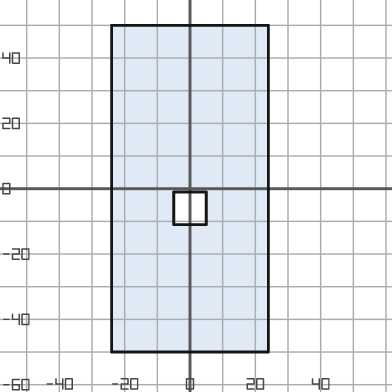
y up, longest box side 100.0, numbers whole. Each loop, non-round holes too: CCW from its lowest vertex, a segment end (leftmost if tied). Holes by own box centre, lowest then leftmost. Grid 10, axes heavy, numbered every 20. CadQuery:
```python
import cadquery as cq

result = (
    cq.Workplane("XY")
    .moveTo(-24.0, -50.0)
    .lineTo(24.0, -50.0)
    .lineTo(24.0, 50.0)
    .lineTo(-24.0, 50.0)
    .close()
    .moveTo(-5.0, -11.0)
    .lineTo(5.0, -11.0)
    .lineTo(5.0, -1.0)
    .lineTo(-5.0, -1.0)
    .close()
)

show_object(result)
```